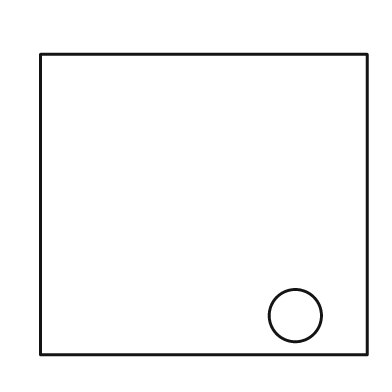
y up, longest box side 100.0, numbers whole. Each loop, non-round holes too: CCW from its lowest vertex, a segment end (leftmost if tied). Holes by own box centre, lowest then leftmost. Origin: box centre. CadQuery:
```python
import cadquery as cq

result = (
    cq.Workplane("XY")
    .moveTo(-50.0, -46.0)
    .lineTo(50.0, -46.0)
    .lineTo(50.0, 46.0)
    .lineTo(-50.0, 46.0)
    .close()
    .moveTo(28.0, -34.0)
    .circle(8.0)
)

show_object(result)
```